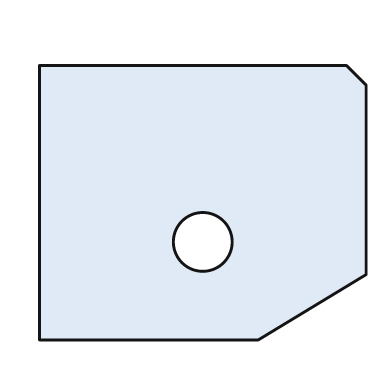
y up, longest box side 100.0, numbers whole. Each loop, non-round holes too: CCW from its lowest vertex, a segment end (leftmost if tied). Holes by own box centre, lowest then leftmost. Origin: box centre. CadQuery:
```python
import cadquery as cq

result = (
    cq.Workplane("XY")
    .moveTo(-50.0, -42.0)
    .lineTo(17.0, -42.0)
    .lineTo(50.0, -22.0)
    .lineTo(50.0, 36.0)
    .lineTo(44.0, 42.0)
    .lineTo(-50.0, 42.0)
    .close()
    .moveTo(0.0, -12.0)
    .circle(9.0)
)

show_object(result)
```